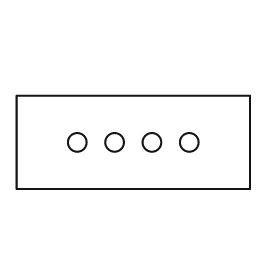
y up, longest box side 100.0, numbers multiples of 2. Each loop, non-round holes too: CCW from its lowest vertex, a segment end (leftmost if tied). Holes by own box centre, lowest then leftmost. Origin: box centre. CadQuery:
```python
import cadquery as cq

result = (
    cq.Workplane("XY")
    .moveTo(-50.0, -20.0)
    .lineTo(50.0, -20.0)
    .lineTo(50.0, 20.0)
    .lineTo(-50.0, 20.0)
    .close()
    .moveTo(-24.0, 0.0)
    .circle(4.0)
    .moveTo(-8.0, 0.0)
    .circle(4.0)
    .moveTo(8.0, 0.0)
    .circle(4.0)
    .moveTo(24.0, 0.0)
    .circle(4.0)
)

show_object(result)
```